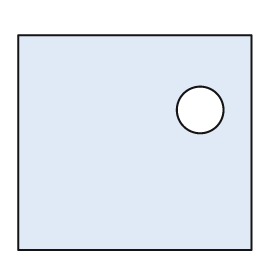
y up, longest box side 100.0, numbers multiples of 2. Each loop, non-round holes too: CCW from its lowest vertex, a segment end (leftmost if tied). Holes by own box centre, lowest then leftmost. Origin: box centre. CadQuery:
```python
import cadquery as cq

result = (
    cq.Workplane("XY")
    .moveTo(-50.0, -46.0)
    .lineTo(50.0, -46.0)
    .lineTo(50.0, 46.0)
    .lineTo(-50.0, 46.0)
    .close()
    .moveTo(28.0, 14.0)
    .circle(10.0)
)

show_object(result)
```